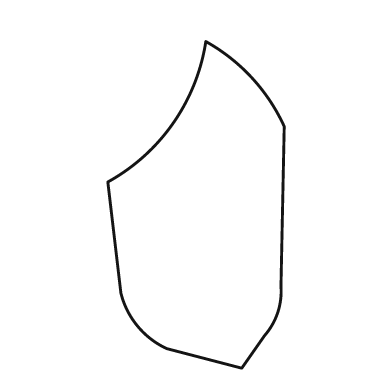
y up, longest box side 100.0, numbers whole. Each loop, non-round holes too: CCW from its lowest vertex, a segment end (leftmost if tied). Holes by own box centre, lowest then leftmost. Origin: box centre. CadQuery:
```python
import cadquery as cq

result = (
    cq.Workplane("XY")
    .moveTo(14.0, -50.0)
    .lineTo(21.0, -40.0)
    .threePointArc((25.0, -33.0), (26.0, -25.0))
    .lineTo(27.0, 24.0)
    .threePointArc((17.0, 39.0), (3.0, 50.0))
    .threePointArc((-7.0, 25.0), (-27.0, 7.0))
    .lineTo(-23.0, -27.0)
    .threePointArc((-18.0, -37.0), (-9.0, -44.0))
    .close()
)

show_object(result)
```